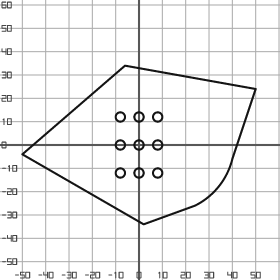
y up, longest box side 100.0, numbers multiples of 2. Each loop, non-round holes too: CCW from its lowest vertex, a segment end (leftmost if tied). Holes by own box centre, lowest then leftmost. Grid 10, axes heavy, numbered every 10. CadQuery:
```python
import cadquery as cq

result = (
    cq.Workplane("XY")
    .moveTo(2.0, -34.0)
    .lineTo(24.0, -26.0)
    .threePointArc((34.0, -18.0), (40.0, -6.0))
    .lineTo(50.0, 24.0)
    .lineTo(-6.0, 34.0)
    .lineTo(-50.0, -4.0)
    .close()
    .moveTo(-8.0, -12.0)
    .circle(2.0)
    .moveTo(0.0, -12.0)
    .circle(2.0)
    .moveTo(8.0, -12.0)
    .circle(2.0)
    .moveTo(-8.0, 0.0)
    .circle(2.0)
    .moveTo(0.0, 0.0)
    .circle(2.0)
    .moveTo(8.0, 0.0)
    .circle(2.0)
    .moveTo(-8.0, 12.0)
    .circle(2.0)
    .moveTo(0.0, 12.0)
    .circle(2.0)
    .moveTo(8.0, 12.0)
    .circle(2.0)
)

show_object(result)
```